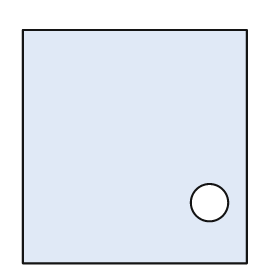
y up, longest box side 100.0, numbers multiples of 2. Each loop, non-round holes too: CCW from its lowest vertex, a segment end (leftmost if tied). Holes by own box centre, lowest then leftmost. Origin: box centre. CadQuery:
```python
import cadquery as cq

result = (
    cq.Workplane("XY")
    .moveTo(-48.0, -50.0)
    .lineTo(48.0, -50.0)
    .lineTo(48.0, 50.0)
    .lineTo(-48.0, 50.0)
    .close()
    .moveTo(32.0, -24.0)
    .circle(8.0)
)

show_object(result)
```